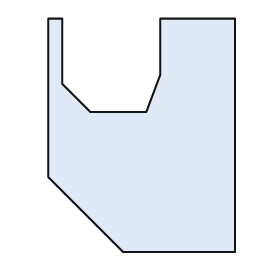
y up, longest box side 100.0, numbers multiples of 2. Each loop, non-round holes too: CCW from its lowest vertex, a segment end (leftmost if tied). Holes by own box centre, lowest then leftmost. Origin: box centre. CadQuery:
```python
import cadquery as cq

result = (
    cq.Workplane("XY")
    .moveTo(-8.0, -50.0)
    .lineTo(40.0, -50.0)
    .lineTo(40.0, 50.0)
    .lineTo(8.0, 50.0)
    .lineTo(8.0, 26.0)
    .lineTo(2.0, 10.0)
    .lineTo(-22.0, 10.0)
    .lineTo(-34.0, 22.0)
    .lineTo(-34.0, 50.0)
    .lineTo(-40.0, 50.0)
    .lineTo(-40.0, -18.0)
    .close()
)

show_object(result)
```